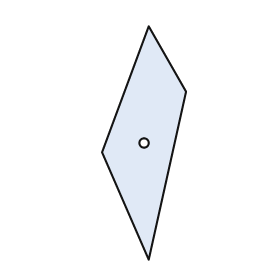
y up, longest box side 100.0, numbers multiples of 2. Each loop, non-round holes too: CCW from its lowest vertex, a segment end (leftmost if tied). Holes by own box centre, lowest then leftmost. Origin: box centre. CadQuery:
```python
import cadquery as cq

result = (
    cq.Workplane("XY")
    .moveTo(2.0, -50.0)
    .lineTo(18.0, 22.0)
    .lineTo(2.0, 50.0)
    .lineTo(-18.0, -4.0)
    .close()
    .moveTo(0.0, 0.0)
    .circle(2.0)
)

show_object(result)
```